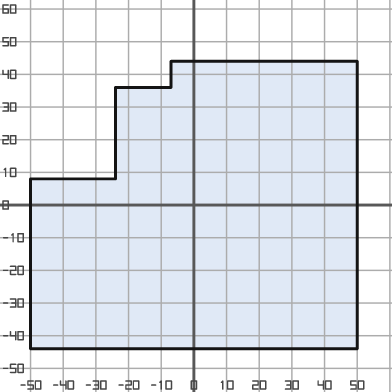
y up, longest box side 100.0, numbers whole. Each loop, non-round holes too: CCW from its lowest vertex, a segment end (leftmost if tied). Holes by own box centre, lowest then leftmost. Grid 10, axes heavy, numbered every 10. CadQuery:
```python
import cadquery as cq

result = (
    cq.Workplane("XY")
    .moveTo(-50.0, -44.0)
    .lineTo(50.0, -44.0)
    .lineTo(50.0, 44.0)
    .lineTo(-7.0, 44.0)
    .lineTo(-7.0, 36.0)
    .lineTo(-24.0, 36.0)
    .lineTo(-24.0, 8.0)
    .lineTo(-50.0, 8.0)
    .close()
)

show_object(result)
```